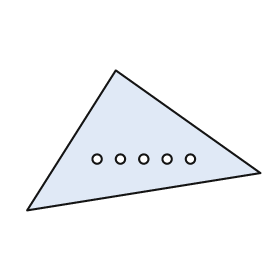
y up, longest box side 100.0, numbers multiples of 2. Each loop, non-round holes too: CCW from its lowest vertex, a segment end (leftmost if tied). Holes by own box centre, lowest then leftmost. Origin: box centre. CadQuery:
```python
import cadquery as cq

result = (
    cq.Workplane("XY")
    .moveTo(-50.0, -30.0)
    .lineTo(50.0, -14.0)
    .lineTo(-12.0, 30.0)
    .close()
    .moveTo(-20.0, -8.0)
    .circle(2.0)
    .moveTo(-10.0, -8.0)
    .circle(2.0)
    .moveTo(0.0, -8.0)
    .circle(2.0)
    .moveTo(10.0, -8.0)
    .circle(2.0)
    .moveTo(20.0, -8.0)
    .circle(2.0)
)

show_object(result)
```